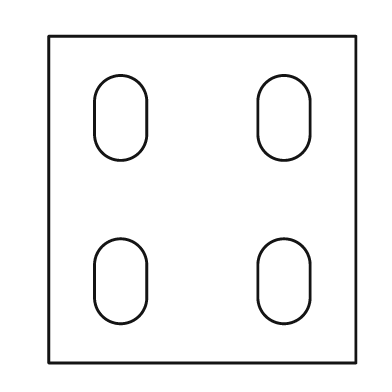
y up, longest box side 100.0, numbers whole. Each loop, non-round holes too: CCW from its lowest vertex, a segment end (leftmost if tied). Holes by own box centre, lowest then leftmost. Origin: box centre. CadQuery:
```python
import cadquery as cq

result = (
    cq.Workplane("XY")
    .moveTo(-47.0, -50.0)
    .lineTo(47.0, -50.0)
    .lineTo(47.0, 50.0)
    .lineTo(-47.0, 50.0)
    .close()
    .moveTo(-33.0, -30.0)
    .threePointArc((-25.0, -38.0), (-17.0, -30.0))
    .lineTo(-17.0, -20.0)
    .threePointArc((-25.0, -12.0), (-33.0, -20.0))
    .close()
    .moveTo(17.0, -30.0)
    .threePointArc((25.0, -38.0), (33.0, -30.0))
    .lineTo(33.0, -20.0)
    .threePointArc((25.0, -12.0), (17.0, -20.0))
    .close()
    .moveTo(-33.0, 20.0)
    .threePointArc((-25.0, 12.0), (-17.0, 20.0))
    .lineTo(-17.0, 30.0)
    .threePointArc((-25.0, 38.0), (-33.0, 30.0))
    .close()
    .moveTo(17.0, 20.0)
    .threePointArc((25.0, 12.0), (33.0, 20.0))
    .lineTo(33.0, 30.0)
    .threePointArc((25.0, 38.0), (17.0, 30.0))
    .close()
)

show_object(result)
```